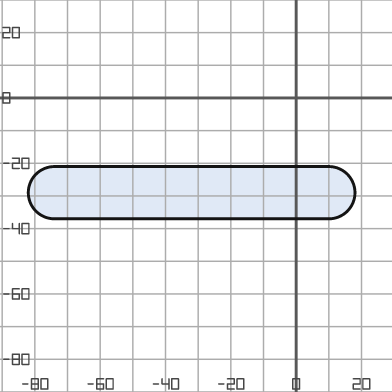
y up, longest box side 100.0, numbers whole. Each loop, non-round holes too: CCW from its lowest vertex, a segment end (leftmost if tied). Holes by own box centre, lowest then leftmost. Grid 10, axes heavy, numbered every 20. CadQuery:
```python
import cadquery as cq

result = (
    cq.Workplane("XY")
    .moveTo(-74.0, -37.0)
    .lineTo(10.0, -37.0)
    .threePointArc((18.0, -29.0), (10.0, -21.0))
    .lineTo(-74.0, -21.0)
    .threePointArc((-82.0, -29.0), (-74.0, -37.0))
    .close()
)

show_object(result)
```